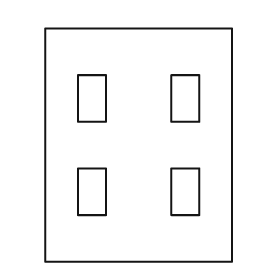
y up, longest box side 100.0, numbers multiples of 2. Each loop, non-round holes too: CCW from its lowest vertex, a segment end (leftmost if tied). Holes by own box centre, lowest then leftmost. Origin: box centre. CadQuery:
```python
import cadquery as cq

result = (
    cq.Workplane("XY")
    .moveTo(-40.0, -50.0)
    .lineTo(40.0, -50.0)
    .lineTo(40.0, 50.0)
    .lineTo(-40.0, 50.0)
    .close()
    .moveTo(-26.0, -30.0)
    .lineTo(-14.0, -30.0)
    .lineTo(-14.0, -10.0)
    .lineTo(-26.0, -10.0)
    .close()
    .moveTo(14.0, -30.0)
    .lineTo(26.0, -30.0)
    .lineTo(26.0, -10.0)
    .lineTo(14.0, -10.0)
    .close()
    .moveTo(-26.0, 10.0)
    .lineTo(-14.0, 10.0)
    .lineTo(-14.0, 30.0)
    .lineTo(-26.0, 30.0)
    .close()
    .moveTo(14.0, 10.0)
    .lineTo(26.0, 10.0)
    .lineTo(26.0, 30.0)
    .lineTo(14.0, 30.0)
    .close()
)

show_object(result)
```